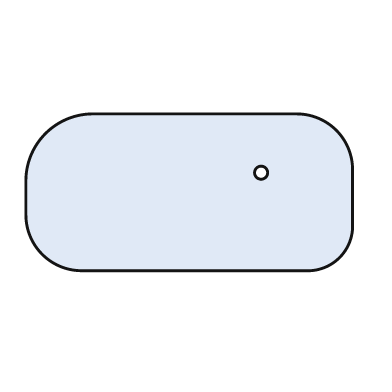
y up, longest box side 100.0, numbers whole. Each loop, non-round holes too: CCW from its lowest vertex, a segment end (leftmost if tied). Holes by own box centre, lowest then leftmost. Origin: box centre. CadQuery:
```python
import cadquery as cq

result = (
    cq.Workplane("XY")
    .moveTo(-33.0, -24.0)
    .lineTo(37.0, -24.0)
    .threePointArc((46.0, -20.0), (50.0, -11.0))
    .lineTo(50.0, 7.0)
    .threePointArc((45.0, 19.0), (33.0, 24.0))
    .lineTo(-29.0, 24.0)
    .threePointArc((-44.0, 18.0), (-50.0, 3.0))
    .lineTo(-50.0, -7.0)
    .threePointArc((-45.0, -19.0), (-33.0, -24.0))
    .close()
    .moveTo(22.0, 6.0)
    .circle(2.0)
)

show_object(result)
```